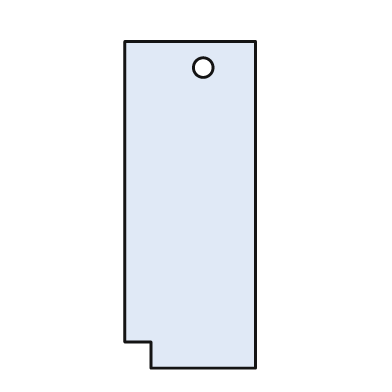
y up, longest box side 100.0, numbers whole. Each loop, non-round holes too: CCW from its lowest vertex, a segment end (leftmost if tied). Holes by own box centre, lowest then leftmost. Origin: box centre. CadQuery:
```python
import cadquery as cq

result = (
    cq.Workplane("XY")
    .moveTo(-12.0, -50.0)
    .lineTo(20.0, -50.0)
    .lineTo(20.0, 50.0)
    .lineTo(-20.0, 50.0)
    .lineTo(-20.0, -42.0)
    .lineTo(-12.0, -42.0)
    .close()
    .moveTo(4.0, 42.0)
    .circle(3.0)
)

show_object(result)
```